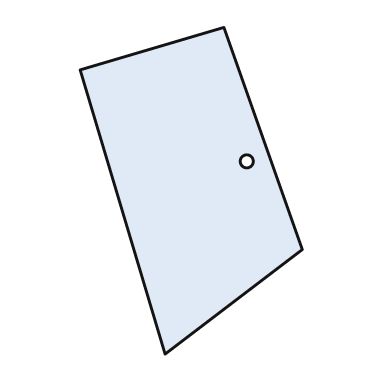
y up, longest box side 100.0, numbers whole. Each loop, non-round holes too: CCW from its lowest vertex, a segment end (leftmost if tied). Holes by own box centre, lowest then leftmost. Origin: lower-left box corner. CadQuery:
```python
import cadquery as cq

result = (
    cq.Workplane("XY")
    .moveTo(26.0, 0.0)
    .lineTo(68.0, 32.0)
    .lineTo(44.0, 100.0)
    .lineTo(0.0, 87.0)
    .close()
    .moveTo(51.0, 59.0)
    .circle(2.0)
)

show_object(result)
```